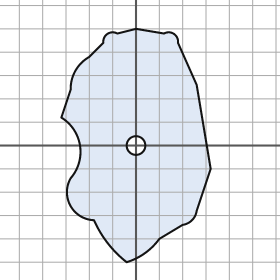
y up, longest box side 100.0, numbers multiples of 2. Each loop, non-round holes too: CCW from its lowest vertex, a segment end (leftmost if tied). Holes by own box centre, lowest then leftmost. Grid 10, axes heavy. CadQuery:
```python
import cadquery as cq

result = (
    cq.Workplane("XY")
    .moveTo(-4.0, -50.0)
    .threePointArc((4.0, -46.0), (10.0, -40.0))
    .lineTo(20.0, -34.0)
    .threePointArc((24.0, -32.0), (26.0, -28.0))
    .lineTo(32.0, -10.0)
    .lineTo(26.0, 26.0)
    .lineTo(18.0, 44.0)
    .threePointArc((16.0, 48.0), (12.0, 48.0))
    .lineTo(0.0, 50.0)
    .lineTo(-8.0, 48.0)
    .threePointArc((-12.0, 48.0), (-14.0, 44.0))
    .lineTo(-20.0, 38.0)
    .threePointArc((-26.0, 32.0), (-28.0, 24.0))
    .lineTo(-32.0, 12.0)
    .threePointArc((-24.0, 0.0), (-28.0, -14.0))
    .threePointArc((-28.0, -26.0), (-18.0, -32.0))
    .threePointArc((-12.0, -42.0), (-4.0, -50.0))
    .close()
    .moveTo(0.0, 0.0)
    .circle(4.0)
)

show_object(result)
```